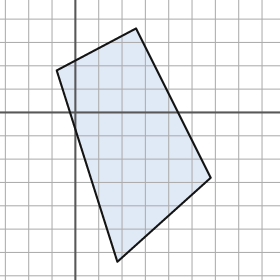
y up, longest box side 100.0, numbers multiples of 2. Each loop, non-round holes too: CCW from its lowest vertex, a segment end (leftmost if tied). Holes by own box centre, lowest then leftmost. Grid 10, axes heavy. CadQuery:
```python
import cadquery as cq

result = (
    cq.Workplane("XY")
    .moveTo(18.0, -64.0)
    .lineTo(58.0, -28.0)
    .lineTo(26.0, 36.0)
    .lineTo(-8.0, 18.0)
    .close()
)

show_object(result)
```